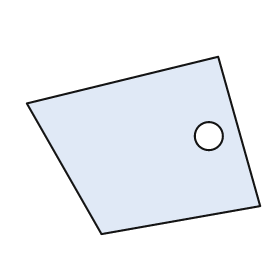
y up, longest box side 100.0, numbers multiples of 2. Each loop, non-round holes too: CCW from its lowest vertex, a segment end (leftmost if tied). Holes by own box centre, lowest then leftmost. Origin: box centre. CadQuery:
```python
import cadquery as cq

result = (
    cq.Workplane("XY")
    .moveTo(-18.0, -38.0)
    .lineTo(50.0, -26.0)
    .lineTo(32.0, 38.0)
    .lineTo(-50.0, 18.0)
    .close()
    .moveTo(28.0, 4.0)
    .circle(6.0)
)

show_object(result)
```